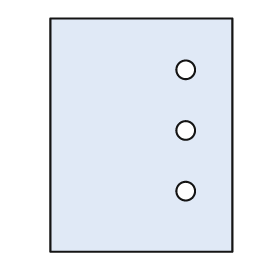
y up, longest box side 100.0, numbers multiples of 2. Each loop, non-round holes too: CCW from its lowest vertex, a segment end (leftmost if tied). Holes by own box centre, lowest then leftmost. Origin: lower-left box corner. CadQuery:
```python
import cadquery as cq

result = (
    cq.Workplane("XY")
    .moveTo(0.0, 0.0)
    .lineTo(78.0, 0.0)
    .lineTo(78.0, 100.0)
    .lineTo(0.0, 100.0)
    .close()
    .moveTo(58.0, 26.0)
    .circle(4.0)
    .moveTo(58.0, 52.0)
    .circle(4.0)
    .moveTo(58.0, 78.0)
    .circle(4.0)
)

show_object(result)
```